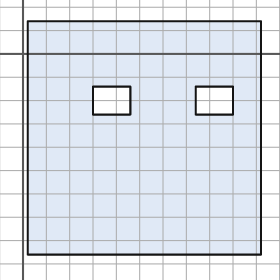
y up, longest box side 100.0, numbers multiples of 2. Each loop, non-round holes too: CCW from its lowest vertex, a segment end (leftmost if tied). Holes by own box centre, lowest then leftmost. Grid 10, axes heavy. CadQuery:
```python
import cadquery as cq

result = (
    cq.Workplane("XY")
    .moveTo(2.0, -86.0)
    .lineTo(102.0, -86.0)
    .lineTo(102.0, 14.0)
    .lineTo(2.0, 14.0)
    .close()
    .moveTo(30.0, -26.0)
    .lineTo(46.0, -26.0)
    .lineTo(46.0, -14.0)
    .lineTo(30.0, -14.0)
    .close()
    .moveTo(74.0, -26.0)
    .lineTo(90.0, -26.0)
    .lineTo(90.0, -14.0)
    .lineTo(74.0, -14.0)
    .close()
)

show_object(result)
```